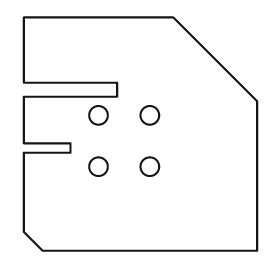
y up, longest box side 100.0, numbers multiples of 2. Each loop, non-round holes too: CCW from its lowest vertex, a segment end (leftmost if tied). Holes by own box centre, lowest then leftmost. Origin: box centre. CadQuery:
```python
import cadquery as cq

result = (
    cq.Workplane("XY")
    .moveTo(-42.0, -50.0)
    .lineTo(50.0, -50.0)
    .lineTo(50.0, 14.0)
    .lineTo(14.0, 50.0)
    .lineTo(-50.0, 50.0)
    .lineTo(-50.0, 22.0)
    .lineTo(-10.0, 22.0)
    .lineTo(-10.0, 16.0)
    .lineTo(-50.0, 16.0)
    .lineTo(-50.0, -4.0)
    .lineTo(-30.0, -4.0)
    .lineTo(-30.0, -8.0)
    .lineTo(-50.0, -8.0)
    .lineTo(-50.0, -42.0)
    .close()
    .moveTo(-18.0, -14.0)
    .circle(4.0)
    .moveTo(4.0, -14.0)
    .circle(4.0)
    .moveTo(-18.0, 8.0)
    .circle(4.0)
    .moveTo(4.0, 8.0)
    .circle(4.0)
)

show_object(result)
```